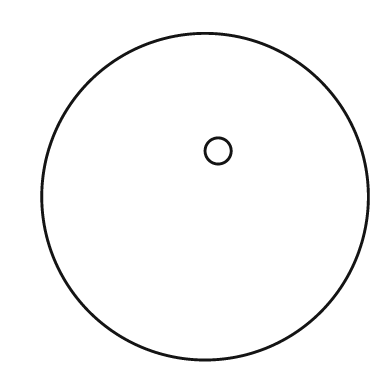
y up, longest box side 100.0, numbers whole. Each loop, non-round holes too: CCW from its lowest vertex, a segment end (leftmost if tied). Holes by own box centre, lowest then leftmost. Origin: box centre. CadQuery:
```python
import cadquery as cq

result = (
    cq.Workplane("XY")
    .moveTo(0.0, 0.0)
    .circle(50.0)
    .moveTo(4.0, 14.0)
    .circle(4.0)
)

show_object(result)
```